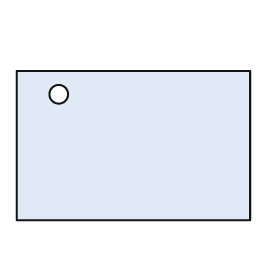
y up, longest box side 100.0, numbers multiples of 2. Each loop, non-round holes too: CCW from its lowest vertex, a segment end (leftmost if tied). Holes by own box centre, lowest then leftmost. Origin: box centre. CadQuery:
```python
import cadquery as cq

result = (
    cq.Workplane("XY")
    .moveTo(-50.0, -32.0)
    .lineTo(50.0, -32.0)
    .lineTo(50.0, 32.0)
    .lineTo(-50.0, 32.0)
    .close()
    .moveTo(-32.0, 22.0)
    .circle(4.0)
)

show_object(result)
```